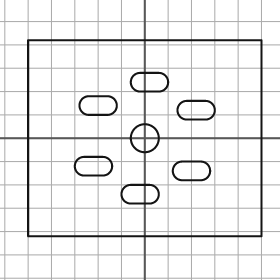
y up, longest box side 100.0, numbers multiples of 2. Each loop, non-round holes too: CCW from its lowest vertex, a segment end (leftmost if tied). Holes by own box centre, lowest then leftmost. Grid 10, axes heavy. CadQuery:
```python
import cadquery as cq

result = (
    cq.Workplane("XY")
    .moveTo(-50.0, -42.0)
    .lineTo(50.0, -42.0)
    .lineTo(50.0, 42.0)
    .lineTo(-50.0, 42.0)
    .close()
    .moveTo(-6.0, -28.0)
    .lineTo(2.0, -28.0)
    .threePointArc((6.0, -24.0), (2.0, -20.0))
    .lineTo(-6.0, -20.0)
    .threePointArc((-10.0, -24.0), (-6.0, -28.0))
    .close()
    .moveTo(16.0, -18.0)
    .lineTo(24.0, -18.0)
    .threePointArc((28.0, -14.0), (24.0, -10.0))
    .lineTo(16.0, -10.0)
    .threePointArc((12.0, -14.0), (16.0, -18.0))
    .close()
    .moveTo(-26.0, -16.0)
    .lineTo(-18.0, -16.0)
    .threePointArc((-14.0, -12.0), (-18.0, -8.0))
    .lineTo(-26.0, -8.0)
    .threePointArc((-30.0, -12.0), (-26.0, -16.0))
    .close()
    .moveTo(0.0, 0.0)
    .circle(6.0)
    .moveTo(18.0, 8.0)
    .lineTo(26.0, 8.0)
    .threePointArc((30.0, 12.0), (26.0, 16.0))
    .lineTo(18.0, 16.0)
    .threePointArc((14.0, 12.0), (18.0, 8.0))
    .close()
    .moveTo(-24.0, 10.0)
    .lineTo(-16.0, 10.0)
    .threePointArc((-12.0, 14.0), (-16.0, 18.0))
    .lineTo(-24.0, 18.0)
    .threePointArc((-28.0, 14.0), (-24.0, 10.0))
    .close()
    .moveTo(-2.0, 20.0)
    .lineTo(6.0, 20.0)
    .threePointArc((10.0, 24.0), (6.0, 28.0))
    .lineTo(-2.0, 28.0)
    .threePointArc((-6.0, 24.0), (-2.0, 20.0))
    .close()
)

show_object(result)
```